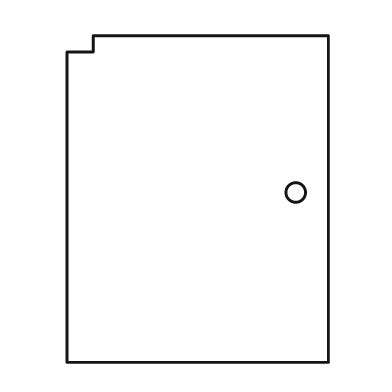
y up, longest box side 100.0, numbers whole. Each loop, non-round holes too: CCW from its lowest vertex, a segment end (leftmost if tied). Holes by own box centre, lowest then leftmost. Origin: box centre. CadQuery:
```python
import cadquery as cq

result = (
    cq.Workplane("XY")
    .moveTo(-40.0, -50.0)
    .lineTo(40.0, -50.0)
    .lineTo(40.0, 50.0)
    .lineTo(-32.0, 50.0)
    .lineTo(-32.0, 45.0)
    .lineTo(-40.0, 45.0)
    .close()
    .moveTo(30.0, 2.0)
    .circle(3.0)
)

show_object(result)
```